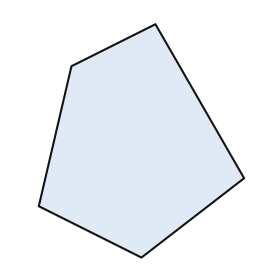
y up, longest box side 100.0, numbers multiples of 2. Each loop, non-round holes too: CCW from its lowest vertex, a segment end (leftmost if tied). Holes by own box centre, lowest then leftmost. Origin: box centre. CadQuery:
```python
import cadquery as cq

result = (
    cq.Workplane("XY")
    .moveTo(0.0, -50.0)
    .lineTo(44.0, -16.0)
    .lineTo(6.0, 50.0)
    .lineTo(-30.0, 32.0)
    .lineTo(-44.0, -28.0)
    .close()
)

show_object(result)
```